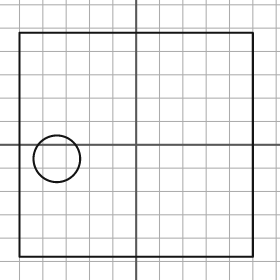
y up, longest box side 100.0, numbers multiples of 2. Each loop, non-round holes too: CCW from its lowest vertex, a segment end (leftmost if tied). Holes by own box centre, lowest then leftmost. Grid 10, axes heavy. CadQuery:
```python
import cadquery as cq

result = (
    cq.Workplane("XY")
    .moveTo(-50.0, -48.0)
    .lineTo(50.0, -48.0)
    .lineTo(50.0, 48.0)
    .lineTo(-50.0, 48.0)
    .close()
    .moveTo(-34.0, -6.0)
    .circle(10.0)
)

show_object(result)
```